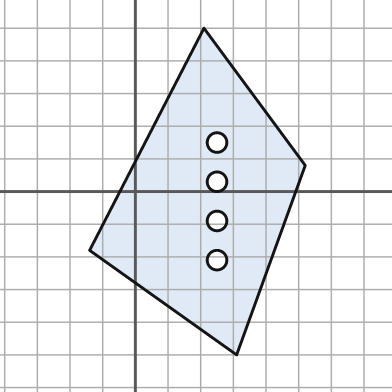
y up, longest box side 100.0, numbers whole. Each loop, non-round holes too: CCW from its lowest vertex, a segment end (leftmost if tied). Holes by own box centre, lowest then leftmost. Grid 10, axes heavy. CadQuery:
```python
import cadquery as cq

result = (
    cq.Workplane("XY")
    .moveTo(31.0, -50.0)
    .lineTo(52.0, 8.0)
    .lineTo(21.0, 50.0)
    .lineTo(-14.0, -18.0)
    .close()
    .moveTo(25.0, -21.0)
    .circle(3.0)
    .moveTo(25.0, -9.0)
    .circle(3.0)
    .moveTo(25.0, 3.0)
    .circle(3.0)
    .moveTo(25.0, 15.0)
    .circle(3.0)
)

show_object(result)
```